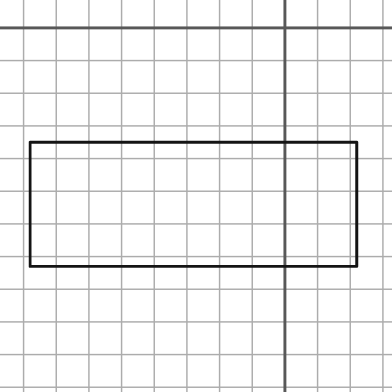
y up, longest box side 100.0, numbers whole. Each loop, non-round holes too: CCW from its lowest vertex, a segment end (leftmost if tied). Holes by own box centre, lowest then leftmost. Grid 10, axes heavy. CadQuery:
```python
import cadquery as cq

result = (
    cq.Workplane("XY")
    .moveTo(-78.0, -73.0)
    .lineTo(22.0, -73.0)
    .lineTo(22.0, -35.0)
    .lineTo(-78.0, -35.0)
    .close()
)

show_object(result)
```